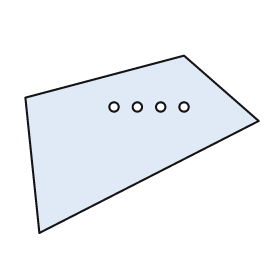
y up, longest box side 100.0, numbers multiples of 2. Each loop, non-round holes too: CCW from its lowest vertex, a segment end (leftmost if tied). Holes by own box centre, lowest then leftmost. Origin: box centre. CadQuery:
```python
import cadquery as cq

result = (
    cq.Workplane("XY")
    .moveTo(-44.0, -38.0)
    .lineTo(50.0, 10.0)
    .lineTo(18.0, 38.0)
    .lineTo(-50.0, 20.0)
    .close()
    .moveTo(-12.0, 16.0)
    .circle(2.0)
    .moveTo(-2.0, 16.0)
    .circle(2.0)
    .moveTo(8.0, 16.0)
    .circle(2.0)
    .moveTo(18.0, 16.0)
    .circle(2.0)
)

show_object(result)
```